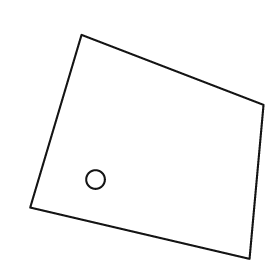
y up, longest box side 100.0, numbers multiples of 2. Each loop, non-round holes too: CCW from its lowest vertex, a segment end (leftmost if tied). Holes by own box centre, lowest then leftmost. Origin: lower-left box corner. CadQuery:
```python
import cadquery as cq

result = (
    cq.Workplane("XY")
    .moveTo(94.0, 0.0)
    .lineTo(100.0, 66.0)
    .lineTo(22.0, 96.0)
    .lineTo(0.0, 22.0)
    .close()
    .moveTo(28.0, 34.0)
    .circle(4.0)
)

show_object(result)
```